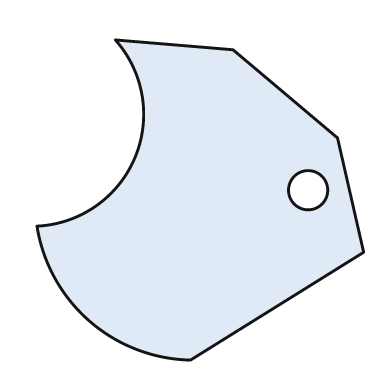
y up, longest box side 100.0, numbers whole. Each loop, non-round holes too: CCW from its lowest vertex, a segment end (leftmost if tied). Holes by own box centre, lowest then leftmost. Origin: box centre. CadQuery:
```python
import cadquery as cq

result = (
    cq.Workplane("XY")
    .moveTo(-3.0, -49.0)
    .lineTo(50.0, -16.0)
    .lineTo(42.0, 19.0)
    .lineTo(10.0, 46.0)
    .lineTo(-26.0, 49.0)
    .threePointArc((-20.0, 13.0), (-50.0, -8.0))
    .threePointArc((-34.0, -37.0), (-3.0, -49.0))
    .close()
    .moveTo(33.0, 3.0)
    .circle(6.0)
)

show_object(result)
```